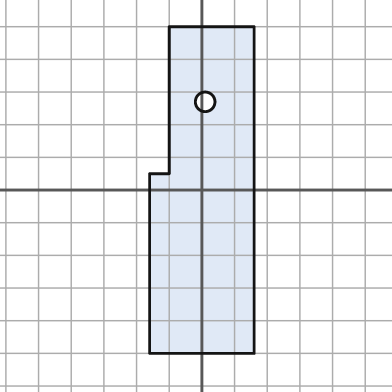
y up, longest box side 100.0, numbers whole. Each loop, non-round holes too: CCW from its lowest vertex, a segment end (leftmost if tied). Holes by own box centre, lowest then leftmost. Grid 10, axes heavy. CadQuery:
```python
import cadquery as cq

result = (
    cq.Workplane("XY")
    .moveTo(-16.0, -50.0)
    .lineTo(16.0, -50.0)
    .lineTo(16.0, 50.0)
    .lineTo(-10.0, 50.0)
    .lineTo(-10.0, 5.0)
    .lineTo(-16.0, 5.0)
    .close()
    .moveTo(1.0, 27.0)
    .circle(3.0)
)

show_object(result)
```